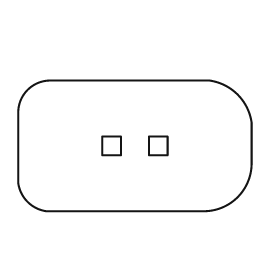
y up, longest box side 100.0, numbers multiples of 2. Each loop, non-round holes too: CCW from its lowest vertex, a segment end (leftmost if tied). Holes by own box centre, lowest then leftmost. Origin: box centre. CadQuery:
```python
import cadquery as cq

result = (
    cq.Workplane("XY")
    .moveTo(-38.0, -28.0)
    .lineTo(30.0, -28.0)
    .threePointArc((44.0, -22.0), (50.0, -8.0))
    .lineTo(50.0, 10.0)
    .threePointArc((44.0, 22.0), (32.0, 28.0))
    .lineTo(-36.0, 28.0)
    .threePointArc((-46.0, 24.0), (-50.0, 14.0))
    .lineTo(-50.0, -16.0)
    .threePointArc((-46.0, -24.0), (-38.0, -28.0))
    .close()
    .moveTo(-14.0, -4.0)
    .lineTo(-6.0, -4.0)
    .lineTo(-6.0, 4.0)
    .lineTo(-14.0, 4.0)
    .close()
    .moveTo(6.0, -4.0)
    .lineTo(14.0, -4.0)
    .lineTo(14.0, 4.0)
    .lineTo(6.0, 4.0)
    .close()
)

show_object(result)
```